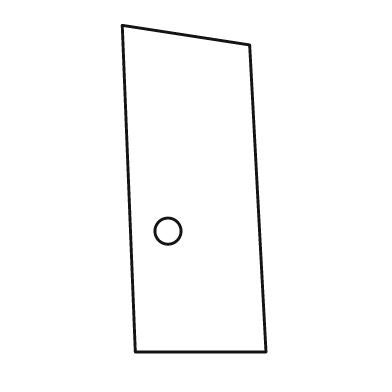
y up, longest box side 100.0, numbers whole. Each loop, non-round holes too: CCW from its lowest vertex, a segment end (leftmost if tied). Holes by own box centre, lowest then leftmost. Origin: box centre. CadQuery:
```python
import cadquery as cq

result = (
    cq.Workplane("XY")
    .moveTo(-18.0, -50.0)
    .lineTo(22.0, -50.0)
    .lineTo(17.0, 44.0)
    .lineTo(-22.0, 50.0)
    .close()
    .moveTo(-8.0, -13.0)
    .circle(4.0)
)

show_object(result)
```